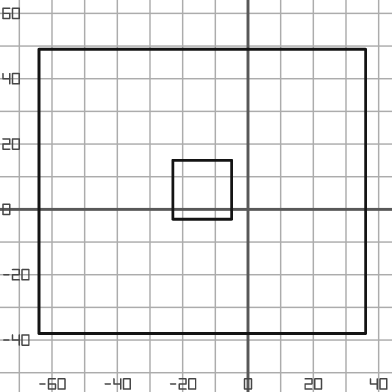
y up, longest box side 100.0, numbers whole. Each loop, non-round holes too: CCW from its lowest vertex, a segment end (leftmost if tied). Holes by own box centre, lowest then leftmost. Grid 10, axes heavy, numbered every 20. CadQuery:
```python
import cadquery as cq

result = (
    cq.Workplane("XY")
    .moveTo(-64.0, -38.0)
    .lineTo(36.0, -38.0)
    .lineTo(36.0, 49.0)
    .lineTo(-64.0, 49.0)
    .close()
    .moveTo(-23.0, -3.0)
    .lineTo(-5.0, -3.0)
    .lineTo(-5.0, 15.0)
    .lineTo(-23.0, 15.0)
    .close()
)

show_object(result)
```